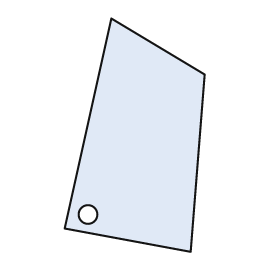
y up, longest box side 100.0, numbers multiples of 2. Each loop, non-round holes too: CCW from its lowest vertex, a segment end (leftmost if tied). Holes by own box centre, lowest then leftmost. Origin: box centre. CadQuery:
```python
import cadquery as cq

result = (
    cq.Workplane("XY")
    .moveTo(24.0, -50.0)
    .lineTo(30.0, 26.0)
    .lineTo(-10.0, 50.0)
    .lineTo(-30.0, -40.0)
    .close()
    .moveTo(-20.0, -34.0)
    .circle(4.0)
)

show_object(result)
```